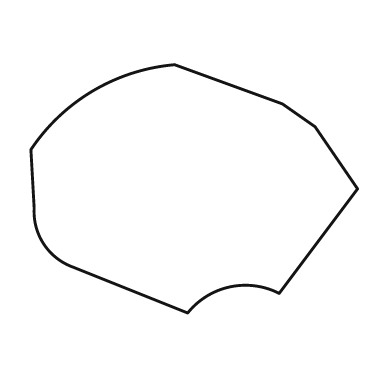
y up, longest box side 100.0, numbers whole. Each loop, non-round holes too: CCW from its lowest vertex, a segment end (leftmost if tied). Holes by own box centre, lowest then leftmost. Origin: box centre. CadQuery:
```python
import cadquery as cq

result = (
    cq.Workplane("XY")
    .moveTo(-2.0, -38.0)
    .threePointArc((11.0, -30.0), (26.0, -32.0))
    .lineTo(50.0, 0.0)
    .lineTo(37.0, 19.0)
    .lineTo(27.0, 26.0)
    .lineTo(-6.0, 38.0)
    .threePointArc((-31.0, 30.0), (-50.0, 12.0))
    .lineTo(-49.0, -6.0)
    .threePointArc((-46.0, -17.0), (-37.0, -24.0))
    .close()
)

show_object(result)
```